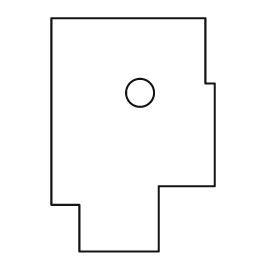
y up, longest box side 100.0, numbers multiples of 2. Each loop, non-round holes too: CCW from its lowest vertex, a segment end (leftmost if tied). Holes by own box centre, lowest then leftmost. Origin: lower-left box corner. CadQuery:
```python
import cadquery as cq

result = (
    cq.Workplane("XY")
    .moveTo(12.0, 0.0)
    .lineTo(46.0, 0.0)
    .lineTo(46.0, 28.0)
    .lineTo(70.0, 28.0)
    .lineTo(70.0, 72.0)
    .lineTo(66.0, 72.0)
    .lineTo(66.0, 100.0)
    .lineTo(0.0, 100.0)
    .lineTo(0.0, 20.0)
    .lineTo(12.0, 20.0)
    .close()
    .moveTo(38.0, 68.0)
    .circle(6.0)
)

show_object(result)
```